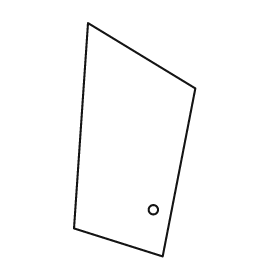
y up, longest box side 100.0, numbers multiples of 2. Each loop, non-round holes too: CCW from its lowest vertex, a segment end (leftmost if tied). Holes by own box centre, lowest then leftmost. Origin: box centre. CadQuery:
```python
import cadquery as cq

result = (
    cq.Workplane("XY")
    .moveTo(12.0, -50.0)
    .lineTo(26.0, 22.0)
    .lineTo(-20.0, 50.0)
    .lineTo(-26.0, -38.0)
    .close()
    .moveTo(8.0, -30.0)
    .circle(2.0)
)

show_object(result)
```